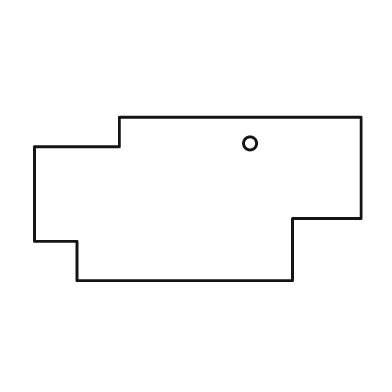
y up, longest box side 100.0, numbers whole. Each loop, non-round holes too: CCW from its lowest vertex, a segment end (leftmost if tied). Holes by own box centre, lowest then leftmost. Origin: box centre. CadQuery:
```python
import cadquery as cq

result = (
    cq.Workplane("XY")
    .moveTo(-37.0, -25.0)
    .lineTo(29.0, -25.0)
    .lineTo(29.0, -6.0)
    .lineTo(50.0, -6.0)
    .lineTo(50.0, 25.0)
    .lineTo(-24.0, 25.0)
    .lineTo(-24.0, 16.0)
    .lineTo(-50.0, 16.0)
    .lineTo(-50.0, -13.0)
    .lineTo(-37.0, -13.0)
    .close()
    .moveTo(16.0, 17.0)
    .circle(2.0)
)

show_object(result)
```